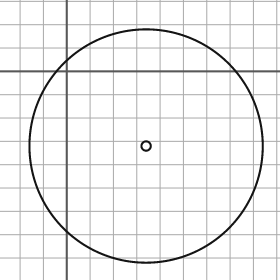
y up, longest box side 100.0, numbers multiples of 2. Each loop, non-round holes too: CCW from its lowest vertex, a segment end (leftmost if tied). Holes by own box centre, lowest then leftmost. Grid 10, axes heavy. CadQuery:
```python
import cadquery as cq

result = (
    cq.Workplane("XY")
    .moveTo(34.0, -32.0)
    .circle(50.0)
    .moveTo(34.0, -32.0)
    .circle(2.0)
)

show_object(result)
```